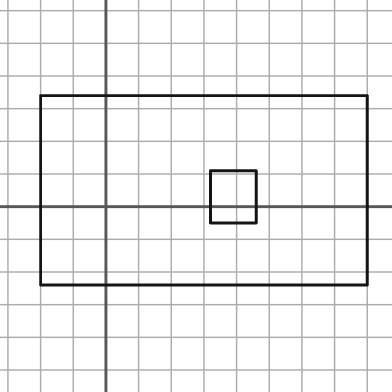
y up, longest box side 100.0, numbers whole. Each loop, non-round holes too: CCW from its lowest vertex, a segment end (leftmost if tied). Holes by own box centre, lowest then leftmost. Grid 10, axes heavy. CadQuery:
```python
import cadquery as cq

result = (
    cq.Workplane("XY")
    .moveTo(-20.0, -24.0)
    .lineTo(80.0, -24.0)
    .lineTo(80.0, 34.0)
    .lineTo(-20.0, 34.0)
    .close()
    .moveTo(32.0, -5.0)
    .lineTo(46.0, -5.0)
    .lineTo(46.0, 11.0)
    .lineTo(32.0, 11.0)
    .close()
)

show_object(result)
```